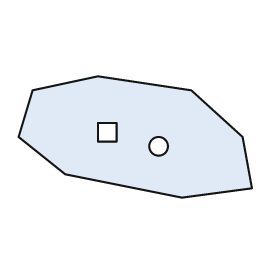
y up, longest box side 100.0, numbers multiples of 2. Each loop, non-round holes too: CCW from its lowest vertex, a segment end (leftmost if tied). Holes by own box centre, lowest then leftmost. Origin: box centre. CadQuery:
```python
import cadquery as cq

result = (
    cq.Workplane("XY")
    .moveTo(20.0, -26.0)
    .lineTo(50.0, -22.0)
    .lineTo(46.0, 0.0)
    .lineTo(24.0, 20.0)
    .lineTo(-16.0, 26.0)
    .lineTo(-44.0, 20.0)
    .lineTo(-50.0, 0.0)
    .lineTo(-30.0, -16.0)
    .close()
    .moveTo(10.0, -4.0)
    .circle(4.0)
    .moveTo(-16.0, -2.0)
    .lineTo(-8.0, -2.0)
    .lineTo(-8.0, 6.0)
    .lineTo(-16.0, 6.0)
    .close()
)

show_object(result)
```